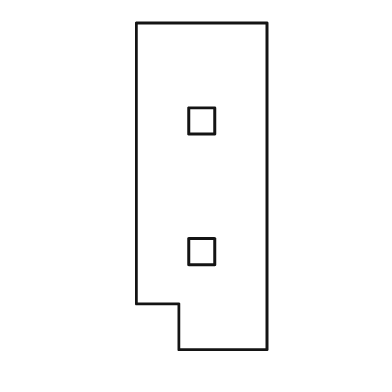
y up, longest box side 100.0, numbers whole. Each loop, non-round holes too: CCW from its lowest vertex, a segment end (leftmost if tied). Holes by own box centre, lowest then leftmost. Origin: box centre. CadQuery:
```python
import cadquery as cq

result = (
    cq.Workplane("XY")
    .moveTo(-7.0, -50.0)
    .lineTo(20.0, -50.0)
    .lineTo(20.0, 50.0)
    .lineTo(-20.0, 50.0)
    .lineTo(-20.0, -36.0)
    .lineTo(-7.0, -36.0)
    .close()
    .moveTo(-4.0, -24.0)
    .lineTo(4.0, -24.0)
    .lineTo(4.0, -16.0)
    .lineTo(-4.0, -16.0)
    .close()
    .moveTo(-4.0, 16.0)
    .lineTo(4.0, 16.0)
    .lineTo(4.0, 24.0)
    .lineTo(-4.0, 24.0)
    .close()
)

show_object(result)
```